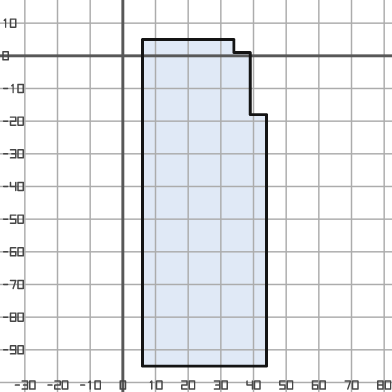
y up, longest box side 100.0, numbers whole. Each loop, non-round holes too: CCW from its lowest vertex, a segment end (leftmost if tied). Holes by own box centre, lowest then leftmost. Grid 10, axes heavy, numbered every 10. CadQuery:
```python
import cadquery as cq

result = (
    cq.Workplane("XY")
    .moveTo(6.0, -95.0)
    .lineTo(44.0, -95.0)
    .lineTo(44.0, -18.0)
    .lineTo(39.0, -18.0)
    .lineTo(39.0, 1.0)
    .lineTo(34.0, 1.0)
    .lineTo(34.0, 5.0)
    .lineTo(6.0, 5.0)
    .close()
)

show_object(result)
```